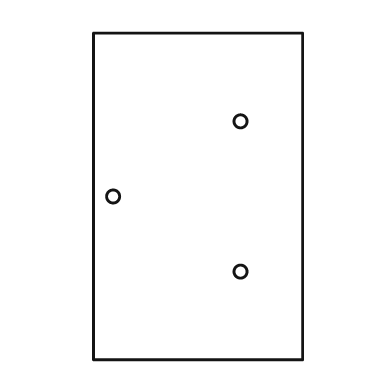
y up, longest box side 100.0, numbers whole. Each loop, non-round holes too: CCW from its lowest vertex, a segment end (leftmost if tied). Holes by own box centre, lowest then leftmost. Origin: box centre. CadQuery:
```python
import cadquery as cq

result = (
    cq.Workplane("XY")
    .moveTo(-32.0, -50.0)
    .lineTo(32.0, -50.0)
    .lineTo(32.0, 50.0)
    .lineTo(-32.0, 50.0)
    .close()
    .moveTo(13.0, -23.0)
    .circle(2.0)
    .moveTo(-26.0, 0.0)
    .circle(2.0)
    .moveTo(13.0, 23.0)
    .circle(2.0)
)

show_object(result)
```